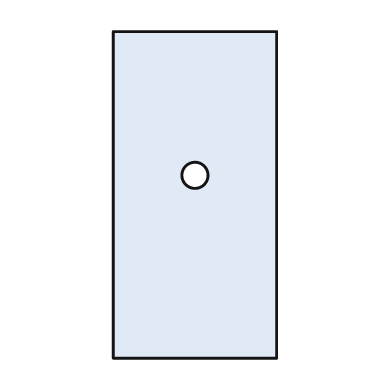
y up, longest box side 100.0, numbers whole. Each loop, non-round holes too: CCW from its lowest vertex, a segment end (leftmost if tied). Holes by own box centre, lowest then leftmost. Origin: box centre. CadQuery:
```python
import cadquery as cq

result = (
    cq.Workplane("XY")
    .moveTo(-25.0, -50.0)
    .lineTo(25.0, -50.0)
    .lineTo(25.0, 50.0)
    .lineTo(-25.0, 50.0)
    .close()
    .moveTo(0.0, 6.0)
    .circle(4.0)
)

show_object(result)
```